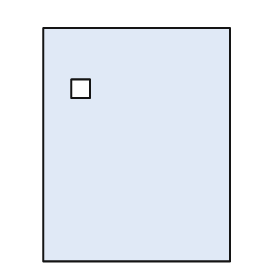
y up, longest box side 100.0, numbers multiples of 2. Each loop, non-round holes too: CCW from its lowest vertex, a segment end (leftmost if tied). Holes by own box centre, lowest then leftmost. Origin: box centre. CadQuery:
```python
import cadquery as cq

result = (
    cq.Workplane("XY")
    .moveTo(-40.0, -50.0)
    .lineTo(40.0, -50.0)
    .lineTo(40.0, 50.0)
    .lineTo(-40.0, 50.0)
    .close()
    .moveTo(-28.0, 20.0)
    .lineTo(-20.0, 20.0)
    .lineTo(-20.0, 28.0)
    .lineTo(-28.0, 28.0)
    .close()
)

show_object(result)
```